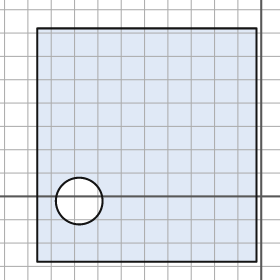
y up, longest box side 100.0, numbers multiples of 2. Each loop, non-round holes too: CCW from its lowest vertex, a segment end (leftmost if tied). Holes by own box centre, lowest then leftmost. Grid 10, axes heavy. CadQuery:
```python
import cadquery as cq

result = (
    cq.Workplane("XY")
    .moveTo(-96.0, -28.0)
    .lineTo(-2.0, -28.0)
    .lineTo(-2.0, 72.0)
    .lineTo(-96.0, 72.0)
    .close()
    .moveTo(-78.0, -2.0)
    .circle(10.0)
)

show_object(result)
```